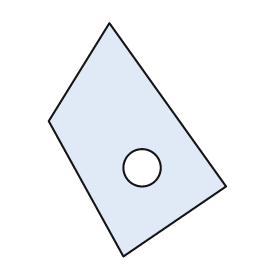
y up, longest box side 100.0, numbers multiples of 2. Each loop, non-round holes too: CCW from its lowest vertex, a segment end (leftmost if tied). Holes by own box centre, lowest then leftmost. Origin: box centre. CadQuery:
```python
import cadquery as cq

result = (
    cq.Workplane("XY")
    .moveTo(-6.0, -50.0)
    .lineTo(38.0, -20.0)
    .lineTo(-12.0, 50.0)
    .lineTo(-38.0, 8.0)
    .close()
    .moveTo(2.0, -12.0)
    .circle(8.0)
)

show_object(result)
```